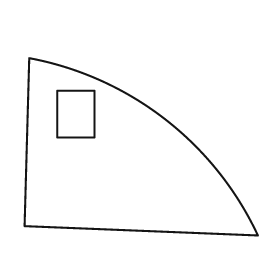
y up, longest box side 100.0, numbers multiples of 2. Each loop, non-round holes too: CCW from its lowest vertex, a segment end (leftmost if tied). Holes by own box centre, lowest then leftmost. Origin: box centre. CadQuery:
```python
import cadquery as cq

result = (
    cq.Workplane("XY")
    .moveTo(50.0, -38.0)
    .threePointArc((10.0, 12.0), (-48.0, 38.0))
    .lineTo(-50.0, -34.0)
    .close()
    .moveTo(-36.0, 4.0)
    .lineTo(-20.0, 4.0)
    .lineTo(-20.0, 24.0)
    .lineTo(-36.0, 24.0)
    .close()
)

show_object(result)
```